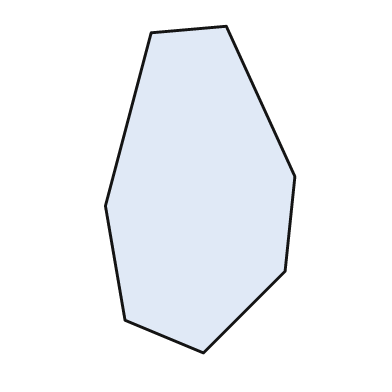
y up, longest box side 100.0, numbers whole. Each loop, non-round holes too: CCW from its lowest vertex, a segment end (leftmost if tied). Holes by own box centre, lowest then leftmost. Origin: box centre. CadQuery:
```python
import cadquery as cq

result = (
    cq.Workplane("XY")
    .moveTo(1.0, -50.0)
    .lineTo(26.0, -25.0)
    .lineTo(29.0, 4.0)
    .lineTo(8.0, 50.0)
    .lineTo(-15.0, 48.0)
    .lineTo(-29.0, -5.0)
    .lineTo(-23.0, -40.0)
    .close()
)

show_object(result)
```